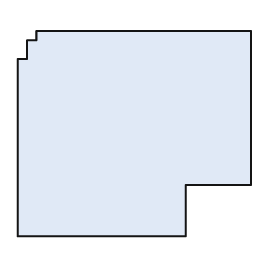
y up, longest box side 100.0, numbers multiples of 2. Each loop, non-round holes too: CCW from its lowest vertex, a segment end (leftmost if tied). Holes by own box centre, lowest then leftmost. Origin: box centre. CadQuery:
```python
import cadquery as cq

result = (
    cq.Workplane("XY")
    .moveTo(-50.0, -44.0)
    .lineTo(22.0, -44.0)
    .lineTo(22.0, -22.0)
    .lineTo(50.0, -22.0)
    .lineTo(50.0, 44.0)
    .lineTo(-42.0, 44.0)
    .lineTo(-42.0, 40.0)
    .lineTo(-46.0, 40.0)
    .lineTo(-46.0, 32.0)
    .lineTo(-50.0, 32.0)
    .close()
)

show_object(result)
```